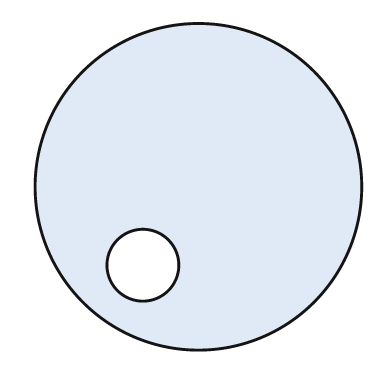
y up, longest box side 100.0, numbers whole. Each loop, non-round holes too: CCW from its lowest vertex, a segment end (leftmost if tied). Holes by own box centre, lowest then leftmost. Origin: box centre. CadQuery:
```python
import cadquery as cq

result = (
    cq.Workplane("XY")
    .moveTo(0.0, 0.0)
    .circle(50.0)
    .moveTo(-17.0, -24.0)
    .circle(11.0)
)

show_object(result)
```